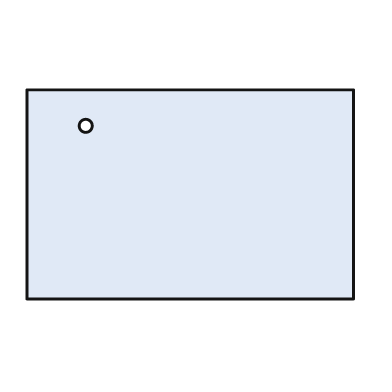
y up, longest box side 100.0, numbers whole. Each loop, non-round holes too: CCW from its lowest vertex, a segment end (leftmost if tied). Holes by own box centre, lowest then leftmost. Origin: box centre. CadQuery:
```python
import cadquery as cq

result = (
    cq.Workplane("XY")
    .moveTo(-50.0, -32.0)
    .lineTo(50.0, -32.0)
    .lineTo(50.0, 32.0)
    .lineTo(-50.0, 32.0)
    .close()
    .moveTo(-32.0, 21.0)
    .circle(2.0)
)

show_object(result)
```